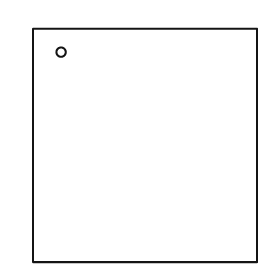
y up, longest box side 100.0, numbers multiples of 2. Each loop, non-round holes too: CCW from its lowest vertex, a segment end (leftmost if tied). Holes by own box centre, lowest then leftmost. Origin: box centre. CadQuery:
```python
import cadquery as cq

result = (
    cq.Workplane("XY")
    .moveTo(-48.0, -50.0)
    .lineTo(48.0, -50.0)
    .lineTo(48.0, 50.0)
    .lineTo(-48.0, 50.0)
    .close()
    .moveTo(-36.0, 40.0)
    .circle(2.0)
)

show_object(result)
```